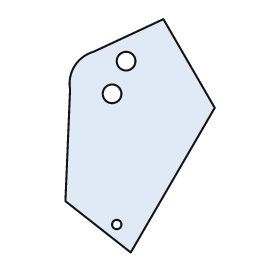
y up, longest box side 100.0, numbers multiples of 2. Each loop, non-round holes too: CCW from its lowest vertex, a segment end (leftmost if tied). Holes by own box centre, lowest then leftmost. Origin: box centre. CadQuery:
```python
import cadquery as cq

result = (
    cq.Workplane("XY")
    .moveTo(-4.0, -50.0)
    .lineTo(32.0, 12.0)
    .lineTo(10.0, 50.0)
    .lineTo(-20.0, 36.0)
    .threePointArc((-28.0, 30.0), (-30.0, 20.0))
    .lineTo(-32.0, -28.0)
    .close()
    .moveTo(-10.0, -38.0)
    .circle(2.0)
    .moveTo(-12.0, 18.0)
    .circle(4.0)
    .moveTo(-6.0, 32.0)
    .circle(4.0)
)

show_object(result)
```